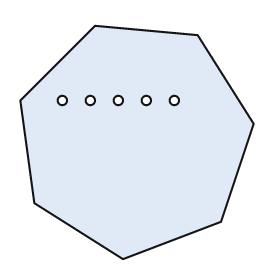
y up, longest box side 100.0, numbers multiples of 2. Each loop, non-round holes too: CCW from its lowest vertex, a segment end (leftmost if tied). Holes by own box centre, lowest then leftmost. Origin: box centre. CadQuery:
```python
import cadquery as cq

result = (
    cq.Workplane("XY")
    .moveTo(-6.0, -50.0)
    .lineTo(36.0, -34.0)
    .lineTo(50.0, 8.0)
    .lineTo(26.0, 46.0)
    .lineTo(-18.0, 50.0)
    .lineTo(-50.0, 18.0)
    .lineTo(-44.0, -26.0)
    .close()
    .moveTo(-32.0, 18.0)
    .circle(2.0)
    .moveTo(-20.0, 18.0)
    .circle(2.0)
    .moveTo(-8.0, 18.0)
    .circle(2.0)
    .moveTo(4.0, 18.0)
    .circle(2.0)
    .moveTo(16.0, 18.0)
    .circle(2.0)
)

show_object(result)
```